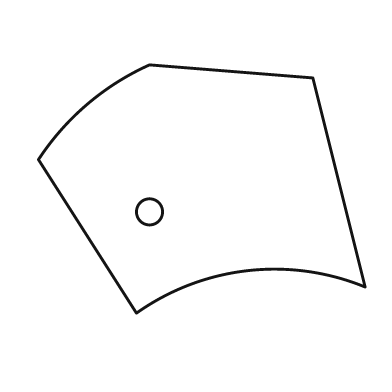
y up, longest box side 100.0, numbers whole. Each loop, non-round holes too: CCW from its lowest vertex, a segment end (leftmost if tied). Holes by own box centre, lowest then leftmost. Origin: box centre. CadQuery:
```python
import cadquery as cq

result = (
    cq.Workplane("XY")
    .moveTo(-20.0, -38.0)
    .threePointArc((14.0, -25.0), (50.0, -30.0))
    .lineTo(34.0, 34.0)
    .lineTo(-16.0, 38.0)
    .threePointArc((-35.0, 26.0), (-50.0, 9.0))
    .close()
    .moveTo(-16.0, -7.0)
    .circle(4.0)
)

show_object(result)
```